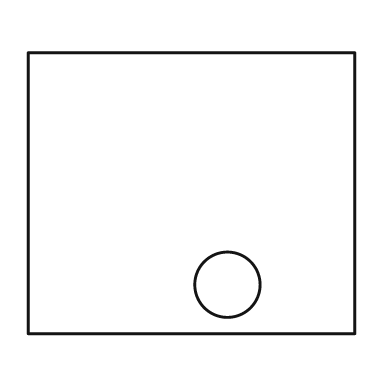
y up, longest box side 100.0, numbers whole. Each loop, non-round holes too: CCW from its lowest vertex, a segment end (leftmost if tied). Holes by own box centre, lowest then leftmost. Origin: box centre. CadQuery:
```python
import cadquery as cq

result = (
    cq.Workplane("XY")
    .moveTo(-50.0, -43.0)
    .lineTo(50.0, -43.0)
    .lineTo(50.0, 43.0)
    .lineTo(-50.0, 43.0)
    .close()
    .moveTo(11.0, -28.0)
    .circle(10.0)
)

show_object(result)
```